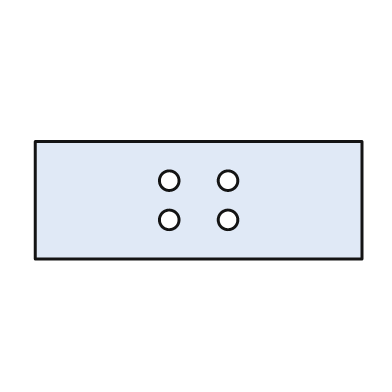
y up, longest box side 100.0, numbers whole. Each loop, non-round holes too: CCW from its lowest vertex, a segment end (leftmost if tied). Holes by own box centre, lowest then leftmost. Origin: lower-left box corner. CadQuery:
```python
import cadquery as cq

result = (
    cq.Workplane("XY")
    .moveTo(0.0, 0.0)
    .lineTo(100.0, 0.0)
    .lineTo(100.0, 36.0)
    .lineTo(0.0, 36.0)
    .close()
    .moveTo(41.0, 12.0)
    .circle(3.0)
    .moveTo(59.0, 12.0)
    .circle(3.0)
    .moveTo(41.0, 24.0)
    .circle(3.0)
    .moveTo(59.0, 24.0)
    .circle(3.0)
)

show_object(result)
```